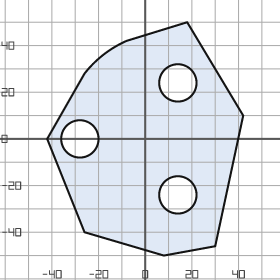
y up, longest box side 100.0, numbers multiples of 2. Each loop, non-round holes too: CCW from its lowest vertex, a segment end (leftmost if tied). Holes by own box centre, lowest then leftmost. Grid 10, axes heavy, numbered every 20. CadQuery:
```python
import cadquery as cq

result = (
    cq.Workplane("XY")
    .moveTo(8.0, -50.0)
    .lineTo(30.0, -46.0)
    .lineTo(42.0, 10.0)
    .lineTo(18.0, 50.0)
    .lineTo(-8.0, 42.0)
    .threePointArc((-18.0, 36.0), (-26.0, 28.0))
    .lineTo(-42.0, 0.0)
    .lineTo(-26.0, -40.0)
    .close()
    .moveTo(14.0, -24.0)
    .circle(8.0)
    .moveTo(-28.0, 0.0)
    .circle(8.0)
    .moveTo(14.0, 24.0)
    .circle(8.0)
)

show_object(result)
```